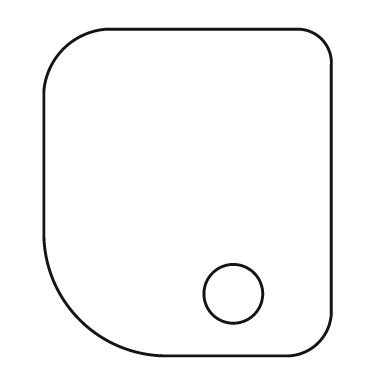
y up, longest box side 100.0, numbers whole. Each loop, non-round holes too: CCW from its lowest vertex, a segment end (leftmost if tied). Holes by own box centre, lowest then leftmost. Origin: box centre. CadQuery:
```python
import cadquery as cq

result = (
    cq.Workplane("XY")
    .moveTo(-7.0, -50.0)
    .lineTo(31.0, -50.0)
    .threePointArc((40.0, -46.0), (44.0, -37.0))
    .lineTo(44.0, 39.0)
    .threePointArc((41.0, 47.0), (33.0, 50.0))
    .lineTo(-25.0, 50.0)
    .threePointArc((-38.0, 44.0), (-44.0, 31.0))
    .lineTo(-44.0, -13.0)
    .threePointArc((-33.0, -39.0), (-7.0, -50.0))
    .close()
    .moveTo(14.0, -31.0)
    .circle(9.0)
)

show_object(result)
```